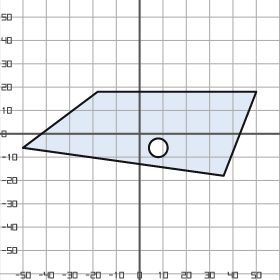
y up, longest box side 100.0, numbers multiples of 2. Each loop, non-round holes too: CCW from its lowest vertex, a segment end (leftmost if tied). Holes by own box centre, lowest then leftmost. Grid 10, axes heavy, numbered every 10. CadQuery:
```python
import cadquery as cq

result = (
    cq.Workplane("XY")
    .moveTo(36.0, -18.0)
    .lineTo(50.0, 18.0)
    .lineTo(-18.0, 18.0)
    .lineTo(-50.0, -6.0)
    .close()
    .moveTo(8.0, -6.0)
    .circle(4.0)
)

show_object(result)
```